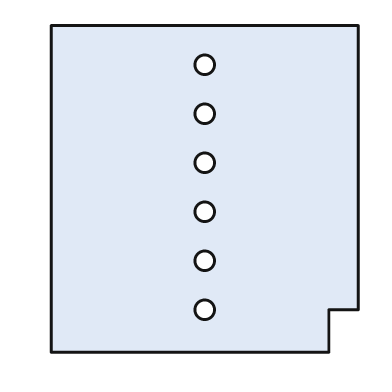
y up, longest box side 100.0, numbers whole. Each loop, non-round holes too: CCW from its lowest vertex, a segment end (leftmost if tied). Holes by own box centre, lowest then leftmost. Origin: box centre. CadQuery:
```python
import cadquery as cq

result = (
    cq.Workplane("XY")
    .moveTo(-47.0, -50.0)
    .lineTo(38.0, -50.0)
    .lineTo(38.0, -37.0)
    .lineTo(47.0, -37.0)
    .lineTo(47.0, 50.0)
    .lineTo(-47.0, 50.0)
    .close()
    .moveTo(0.0, -37.0)
    .circle(3.0)
    .moveTo(0.0, -22.0)
    .circle(3.0)
    .moveTo(0.0, -7.0)
    .circle(3.0)
    .moveTo(0.0, 8.0)
    .circle(3.0)
    .moveTo(0.0, 23.0)
    .circle(3.0)
    .moveTo(0.0, 38.0)
    .circle(3.0)
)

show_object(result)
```